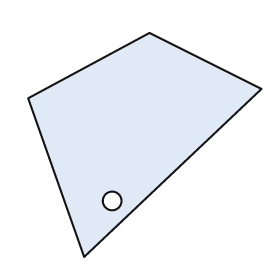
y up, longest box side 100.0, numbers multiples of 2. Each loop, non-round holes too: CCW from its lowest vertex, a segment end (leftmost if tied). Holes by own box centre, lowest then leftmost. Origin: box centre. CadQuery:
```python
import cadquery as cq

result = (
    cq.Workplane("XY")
    .moveTo(-26.0, -48.0)
    .lineTo(50.0, 24.0)
    .lineTo(2.0, 48.0)
    .lineTo(-50.0, 20.0)
    .close()
    .moveTo(-14.0, -24.0)
    .circle(4.0)
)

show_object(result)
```